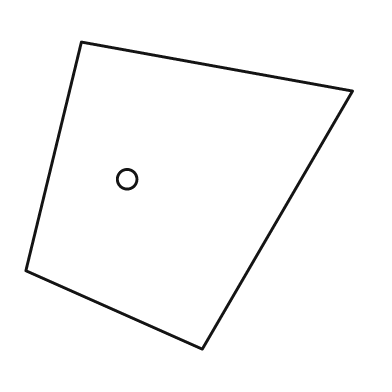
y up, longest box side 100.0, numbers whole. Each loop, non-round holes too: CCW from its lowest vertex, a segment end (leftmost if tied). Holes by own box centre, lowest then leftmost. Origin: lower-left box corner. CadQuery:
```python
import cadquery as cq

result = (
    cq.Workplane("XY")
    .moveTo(54.0, 0.0)
    .lineTo(100.0, 79.0)
    .lineTo(17.0, 94.0)
    .lineTo(0.0, 24.0)
    .close()
    .moveTo(31.0, 52.0)
    .circle(3.0)
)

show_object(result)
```